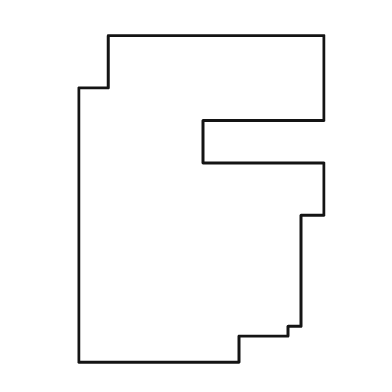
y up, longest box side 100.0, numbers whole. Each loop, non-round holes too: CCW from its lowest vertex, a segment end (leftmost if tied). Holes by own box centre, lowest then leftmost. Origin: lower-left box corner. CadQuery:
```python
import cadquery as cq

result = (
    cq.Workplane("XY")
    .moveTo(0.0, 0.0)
    .lineTo(49.0, 0.0)
    .lineTo(49.0, 8.0)
    .lineTo(64.0, 8.0)
    .lineTo(64.0, 11.0)
    .lineTo(68.0, 11.0)
    .lineTo(68.0, 45.0)
    .lineTo(75.0, 45.0)
    .lineTo(75.0, 61.0)
    .lineTo(38.0, 61.0)
    .lineTo(38.0, 74.0)
    .lineTo(75.0, 74.0)
    .lineTo(75.0, 100.0)
    .lineTo(9.0, 100.0)
    .lineTo(9.0, 84.0)
    .lineTo(0.0, 84.0)
    .close()
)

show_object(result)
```